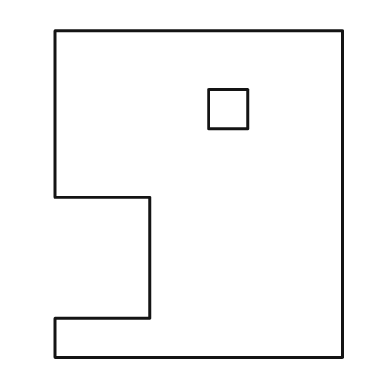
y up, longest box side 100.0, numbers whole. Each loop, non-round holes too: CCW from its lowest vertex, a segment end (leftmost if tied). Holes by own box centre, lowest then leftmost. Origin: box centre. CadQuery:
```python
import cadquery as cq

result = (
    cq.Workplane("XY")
    .moveTo(-44.0, -50.0)
    .lineTo(44.0, -50.0)
    .lineTo(44.0, 50.0)
    .lineTo(-44.0, 50.0)
    .lineTo(-44.0, -1.0)
    .lineTo(-15.0, -1.0)
    .lineTo(-15.0, -38.0)
    .lineTo(-44.0, -38.0)
    .close()
    .moveTo(3.0, 20.0)
    .lineTo(15.0, 20.0)
    .lineTo(15.0, 32.0)
    .lineTo(3.0, 32.0)
    .close()
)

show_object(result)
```